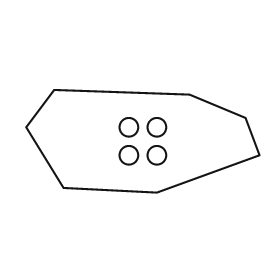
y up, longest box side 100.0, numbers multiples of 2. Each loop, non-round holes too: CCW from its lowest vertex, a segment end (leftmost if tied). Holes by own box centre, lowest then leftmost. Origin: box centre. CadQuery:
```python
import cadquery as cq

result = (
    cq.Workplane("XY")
    .moveTo(6.0, -22.0)
    .lineTo(50.0, -6.0)
    .lineTo(44.0, 10.0)
    .lineTo(20.0, 20.0)
    .lineTo(-38.0, 22.0)
    .lineTo(-50.0, 6.0)
    .lineTo(-34.0, -20.0)
    .close()
    .moveTo(-6.0, -6.0)
    .circle(4.0)
    .moveTo(6.0, -6.0)
    .circle(4.0)
    .moveTo(-6.0, 6.0)
    .circle(4.0)
    .moveTo(6.0, 6.0)
    .circle(4.0)
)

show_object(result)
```